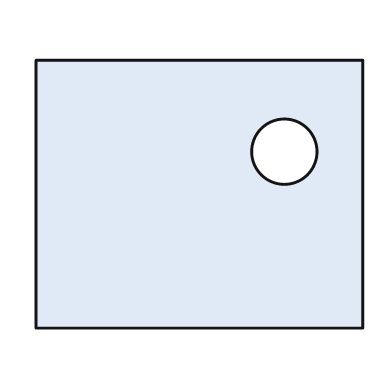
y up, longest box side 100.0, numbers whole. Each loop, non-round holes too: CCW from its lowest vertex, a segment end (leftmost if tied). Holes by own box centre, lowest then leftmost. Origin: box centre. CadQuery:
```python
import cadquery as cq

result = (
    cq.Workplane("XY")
    .moveTo(-50.0, -41.0)
    .lineTo(50.0, -41.0)
    .lineTo(50.0, 41.0)
    .lineTo(-50.0, 41.0)
    .close()
    .moveTo(26.0, 13.0)
    .circle(10.0)
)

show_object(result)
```